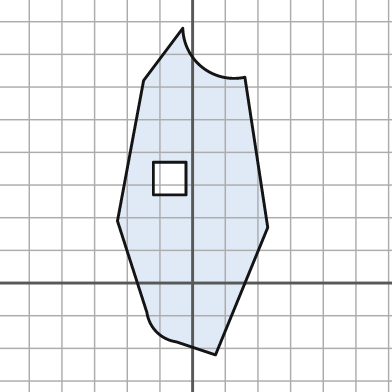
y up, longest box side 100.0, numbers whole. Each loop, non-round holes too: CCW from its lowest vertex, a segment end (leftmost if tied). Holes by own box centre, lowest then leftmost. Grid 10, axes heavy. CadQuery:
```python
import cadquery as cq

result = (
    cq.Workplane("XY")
    .moveTo(7.0, -22.0)
    .lineTo(23.0, 17.0)
    .lineTo(16.0, 63.0)
    .threePointArc((3.0, 66.0), (-3.0, 78.0))
    .lineTo(-15.0, 62.0)
    .lineTo(-23.0, 19.0)
    .lineTo(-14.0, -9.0)
    .threePointArc((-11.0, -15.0), (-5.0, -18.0))
    .close()
    .moveTo(-12.0, 27.0)
    .lineTo(-2.0, 27.0)
    .lineTo(-2.0, 37.0)
    .lineTo(-12.0, 37.0)
    .close()
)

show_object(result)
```